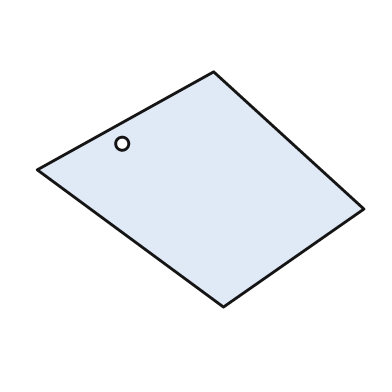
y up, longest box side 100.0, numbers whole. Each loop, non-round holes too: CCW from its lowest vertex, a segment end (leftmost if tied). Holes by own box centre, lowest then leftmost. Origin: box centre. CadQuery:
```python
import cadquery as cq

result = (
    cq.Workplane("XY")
    .moveTo(7.0, -36.0)
    .lineTo(50.0, -6.0)
    .lineTo(4.0, 36.0)
    .lineTo(-50.0, 6.0)
    .close()
    .moveTo(-24.0, 14.0)
    .circle(2.0)
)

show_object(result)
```